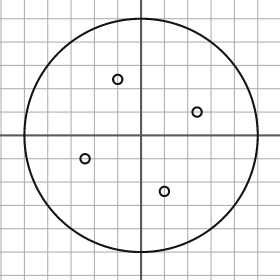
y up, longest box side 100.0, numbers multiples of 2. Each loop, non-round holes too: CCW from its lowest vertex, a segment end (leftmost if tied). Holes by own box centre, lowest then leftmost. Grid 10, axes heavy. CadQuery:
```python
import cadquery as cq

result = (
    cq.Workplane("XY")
    .moveTo(0.0, 0.0)
    .circle(50.0)
    .moveTo(10.0, -24.0)
    .circle(2.0)
    .moveTo(-24.0, -10.0)
    .circle(2.0)
    .moveTo(24.0, 10.0)
    .circle(2.0)
    .moveTo(-10.0, 24.0)
    .circle(2.0)
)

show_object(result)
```